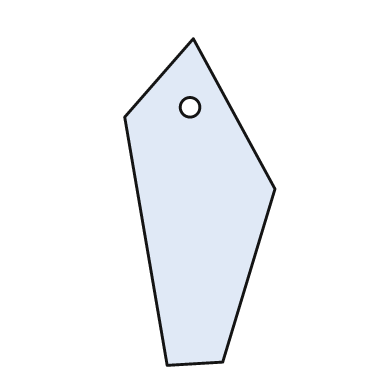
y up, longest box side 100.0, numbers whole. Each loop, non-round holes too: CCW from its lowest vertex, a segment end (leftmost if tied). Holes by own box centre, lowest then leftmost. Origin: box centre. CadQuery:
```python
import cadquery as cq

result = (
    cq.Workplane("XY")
    .moveTo(-10.0, -50.0)
    .lineTo(7.0, -49.0)
    .lineTo(23.0, 4.0)
    .lineTo(-2.0, 50.0)
    .lineTo(-23.0, 26.0)
    .close()
    .moveTo(-3.0, 29.0)
    .circle(3.0)
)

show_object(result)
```